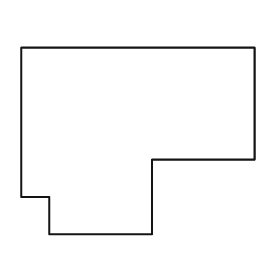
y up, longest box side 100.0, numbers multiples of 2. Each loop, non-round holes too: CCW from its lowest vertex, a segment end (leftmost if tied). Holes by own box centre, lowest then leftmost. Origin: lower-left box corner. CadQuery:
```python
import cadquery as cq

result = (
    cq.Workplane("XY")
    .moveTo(12.0, 0.0)
    .lineTo(56.0, 0.0)
    .lineTo(56.0, 32.0)
    .lineTo(100.0, 32.0)
    .lineTo(100.0, 80.0)
    .lineTo(0.0, 80.0)
    .lineTo(0.0, 16.0)
    .lineTo(12.0, 16.0)
    .close()
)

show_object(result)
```